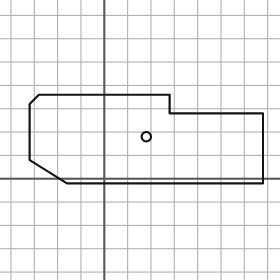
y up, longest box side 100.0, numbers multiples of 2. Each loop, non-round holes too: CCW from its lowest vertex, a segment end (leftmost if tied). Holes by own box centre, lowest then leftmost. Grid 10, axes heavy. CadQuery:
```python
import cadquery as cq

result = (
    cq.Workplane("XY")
    .moveTo(-16.0, -2.0)
    .lineTo(68.0, -2.0)
    .lineTo(68.0, 28.0)
    .lineTo(28.0, 28.0)
    .lineTo(28.0, 36.0)
    .lineTo(-28.0, 36.0)
    .lineTo(-32.0, 32.0)
    .lineTo(-32.0, 8.0)
    .close()
    .moveTo(18.0, 18.0)
    .circle(2.0)
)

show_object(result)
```